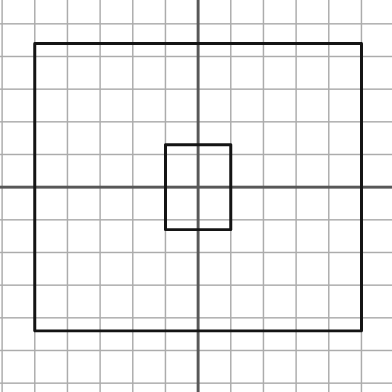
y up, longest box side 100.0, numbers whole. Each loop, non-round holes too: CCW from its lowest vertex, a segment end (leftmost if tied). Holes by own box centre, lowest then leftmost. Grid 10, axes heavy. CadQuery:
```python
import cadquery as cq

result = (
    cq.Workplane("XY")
    .moveTo(-50.0, -44.0)
    .lineTo(50.0, -44.0)
    .lineTo(50.0, 44.0)
    .lineTo(-50.0, 44.0)
    .close()
    .moveTo(-10.0, -13.0)
    .lineTo(10.0, -13.0)
    .lineTo(10.0, 13.0)
    .lineTo(-10.0, 13.0)
    .close()
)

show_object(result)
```